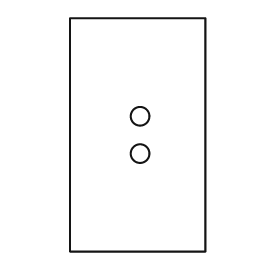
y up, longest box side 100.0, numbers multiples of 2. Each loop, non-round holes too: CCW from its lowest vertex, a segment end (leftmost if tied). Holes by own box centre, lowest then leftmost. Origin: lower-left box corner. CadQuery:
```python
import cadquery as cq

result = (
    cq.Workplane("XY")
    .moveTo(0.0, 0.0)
    .lineTo(58.0, 0.0)
    .lineTo(58.0, 100.0)
    .lineTo(0.0, 100.0)
    .close()
    .moveTo(30.0, 42.0)
    .circle(4.0)
    .moveTo(30.0, 58.0)
    .circle(4.0)
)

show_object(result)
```